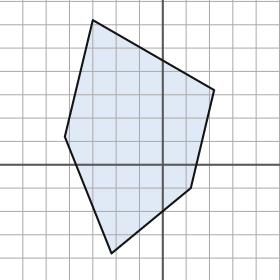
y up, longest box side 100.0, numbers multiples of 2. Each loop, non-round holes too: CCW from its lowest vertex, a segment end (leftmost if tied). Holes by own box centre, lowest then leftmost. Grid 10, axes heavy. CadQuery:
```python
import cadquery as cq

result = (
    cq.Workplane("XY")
    .moveTo(-22.0, -38.0)
    .lineTo(12.0, -10.0)
    .lineTo(22.0, 32.0)
    .lineTo(-30.0, 62.0)
    .lineTo(-42.0, 12.0)
    .close()
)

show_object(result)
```